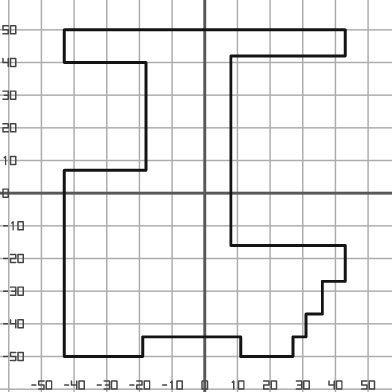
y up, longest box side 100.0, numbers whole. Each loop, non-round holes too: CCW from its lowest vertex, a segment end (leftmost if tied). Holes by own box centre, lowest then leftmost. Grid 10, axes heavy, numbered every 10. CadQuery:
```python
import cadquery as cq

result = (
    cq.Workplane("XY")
    .moveTo(-43.0, -50.0)
    .lineTo(-19.0, -50.0)
    .lineTo(-19.0, -44.0)
    .lineTo(11.0, -44.0)
    .lineTo(11.0, -50.0)
    .lineTo(27.0, -50.0)
    .lineTo(27.0, -44.0)
    .lineTo(31.0, -44.0)
    .lineTo(31.0, -37.0)
    .lineTo(36.0, -37.0)
    .lineTo(36.0, -27.0)
    .lineTo(43.0, -27.0)
    .lineTo(43.0, -16.0)
    .lineTo(8.0, -16.0)
    .lineTo(8.0, 42.0)
    .lineTo(43.0, 42.0)
    .lineTo(43.0, 50.0)
    .lineTo(-43.0, 50.0)
    .lineTo(-43.0, 40.0)
    .lineTo(-18.0, 40.0)
    .lineTo(-18.0, 7.0)
    .lineTo(-43.0, 7.0)
    .close()
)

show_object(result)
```